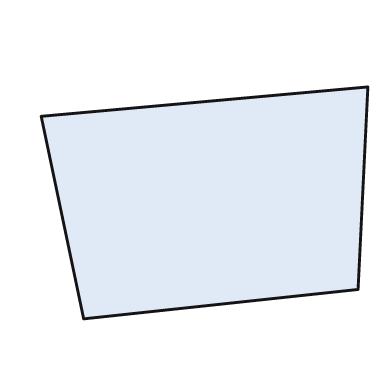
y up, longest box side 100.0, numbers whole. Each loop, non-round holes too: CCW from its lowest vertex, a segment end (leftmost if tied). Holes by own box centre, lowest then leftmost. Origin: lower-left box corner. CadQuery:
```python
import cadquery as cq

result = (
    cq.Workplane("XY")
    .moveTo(13.0, 0.0)
    .lineTo(97.0, 9.0)
    .lineTo(100.0, 71.0)
    .lineTo(0.0, 62.0)
    .close()
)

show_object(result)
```